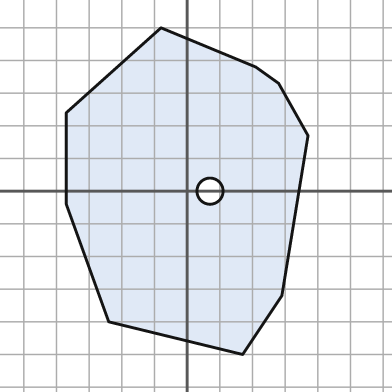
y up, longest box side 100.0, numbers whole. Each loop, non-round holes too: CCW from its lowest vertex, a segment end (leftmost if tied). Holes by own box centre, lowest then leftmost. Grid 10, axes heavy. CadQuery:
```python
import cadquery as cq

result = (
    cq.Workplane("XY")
    .moveTo(17.0, -50.0)
    .lineTo(29.0, -32.0)
    .lineTo(37.0, 17.0)
    .lineTo(28.0, 33.0)
    .lineTo(21.0, 38.0)
    .lineTo(-8.0, 50.0)
    .lineTo(-37.0, 24.0)
    .lineTo(-37.0, -4.0)
    .lineTo(-24.0, -40.0)
    .close()
    .moveTo(7.0, 0.0)
    .circle(4.0)
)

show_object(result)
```